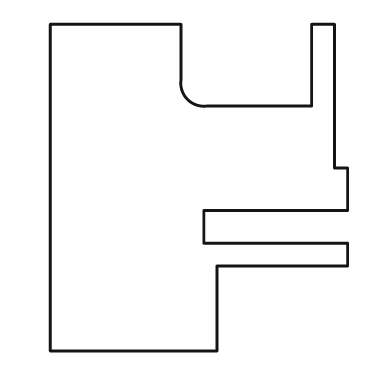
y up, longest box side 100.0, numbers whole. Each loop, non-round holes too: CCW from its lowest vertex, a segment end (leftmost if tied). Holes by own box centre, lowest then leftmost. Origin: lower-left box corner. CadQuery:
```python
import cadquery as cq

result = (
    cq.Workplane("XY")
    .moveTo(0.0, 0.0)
    .lineTo(51.0, 0.0)
    .lineTo(51.0, 26.0)
    .lineTo(91.0, 26.0)
    .lineTo(91.0, 33.0)
    .lineTo(47.0, 33.0)
    .lineTo(47.0, 43.0)
    .lineTo(91.0, 43.0)
    .lineTo(91.0, 56.0)
    .lineTo(87.0, 56.0)
    .lineTo(87.0, 100.0)
    .lineTo(80.0, 100.0)
    .lineTo(80.0, 75.0)
    .lineTo(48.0, 75.0)
    .threePointArc((42.0, 77.0), (40.0, 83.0))
    .lineTo(40.0, 100.0)
    .lineTo(0.0, 100.0)
    .close()
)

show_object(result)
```